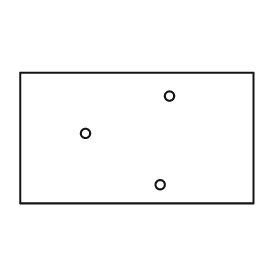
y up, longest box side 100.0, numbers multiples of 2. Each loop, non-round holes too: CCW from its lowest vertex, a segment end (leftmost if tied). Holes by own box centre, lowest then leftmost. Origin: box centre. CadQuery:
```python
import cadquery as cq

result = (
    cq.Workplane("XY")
    .moveTo(-50.0, -28.0)
    .lineTo(50.0, -28.0)
    .lineTo(50.0, 28.0)
    .lineTo(-50.0, 28.0)
    .close()
    .moveTo(10.0, -20.0)
    .circle(2.0)
    .moveTo(-22.0, 2.0)
    .circle(2.0)
    .moveTo(14.0, 18.0)
    .circle(2.0)
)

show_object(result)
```